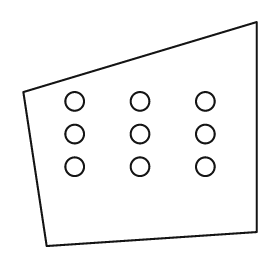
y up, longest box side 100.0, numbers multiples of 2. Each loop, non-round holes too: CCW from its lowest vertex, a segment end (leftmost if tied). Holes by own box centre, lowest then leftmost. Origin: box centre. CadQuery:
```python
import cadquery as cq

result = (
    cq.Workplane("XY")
    .moveTo(-40.0, -48.0)
    .lineTo(50.0, -42.0)
    .lineTo(50.0, 48.0)
    .lineTo(-50.0, 18.0)
    .close()
    .moveTo(-28.0, -14.0)
    .circle(4.0)
    .moveTo(0.0, -14.0)
    .circle(4.0)
    .moveTo(28.0, -14.0)
    .circle(4.0)
    .moveTo(-28.0, 0.0)
    .circle(4.0)
    .moveTo(0.0, 0.0)
    .circle(4.0)
    .moveTo(28.0, 0.0)
    .circle(4.0)
    .moveTo(-28.0, 14.0)
    .circle(4.0)
    .moveTo(0.0, 14.0)
    .circle(4.0)
    .moveTo(28.0, 14.0)
    .circle(4.0)
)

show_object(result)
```